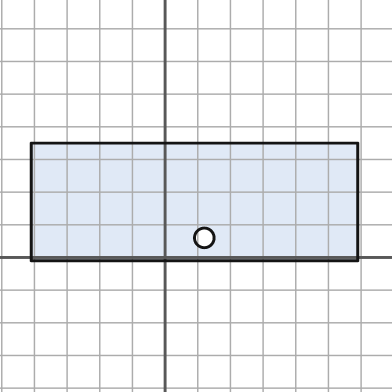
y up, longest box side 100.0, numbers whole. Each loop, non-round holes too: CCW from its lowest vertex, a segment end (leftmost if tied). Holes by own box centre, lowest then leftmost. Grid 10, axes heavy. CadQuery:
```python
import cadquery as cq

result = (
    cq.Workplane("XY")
    .moveTo(-41.0, -1.0)
    .lineTo(59.0, -1.0)
    .lineTo(59.0, 35.0)
    .lineTo(-41.0, 35.0)
    .close()
    .moveTo(12.0, 6.0)
    .circle(3.0)
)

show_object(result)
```